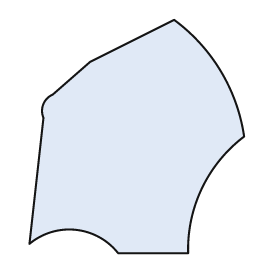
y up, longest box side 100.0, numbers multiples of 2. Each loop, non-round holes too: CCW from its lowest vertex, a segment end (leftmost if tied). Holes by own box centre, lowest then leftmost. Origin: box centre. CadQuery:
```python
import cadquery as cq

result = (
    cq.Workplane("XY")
    .moveTo(-8.0, -50.0)
    .lineTo(22.0, -50.0)
    .threePointArc((28.0, -22.0), (46.0, 0.0))
    .threePointArc((36.0, 28.0), (16.0, 50.0))
    .lineTo(-20.0, 32.0)
    .lineTo(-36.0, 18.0)
    .threePointArc((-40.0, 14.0), (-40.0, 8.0))
    .lineTo(-46.0, -46.0)
    .threePointArc((-26.0, -40.0), (-8.0, -50.0))
    .close()
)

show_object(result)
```